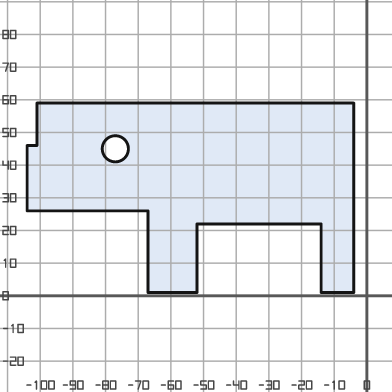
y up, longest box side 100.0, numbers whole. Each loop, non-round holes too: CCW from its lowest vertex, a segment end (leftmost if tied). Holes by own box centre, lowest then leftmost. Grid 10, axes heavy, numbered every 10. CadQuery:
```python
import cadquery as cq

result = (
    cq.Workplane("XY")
    .moveTo(-67.0, 1.0)
    .lineTo(-52.0, 1.0)
    .lineTo(-52.0, 22.0)
    .lineTo(-14.0, 22.0)
    .lineTo(-14.0, 1.0)
    .lineTo(-4.0, 1.0)
    .lineTo(-4.0, 59.0)
    .lineTo(-101.0, 59.0)
    .lineTo(-101.0, 46.0)
    .lineTo(-104.0, 46.0)
    .lineTo(-104.0, 26.0)
    .lineTo(-67.0, 26.0)
    .close()
    .moveTo(-77.0, 45.0)
    .circle(4.0)
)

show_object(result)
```